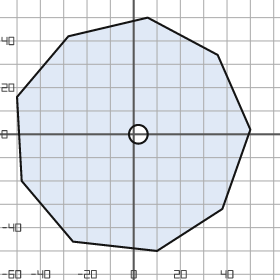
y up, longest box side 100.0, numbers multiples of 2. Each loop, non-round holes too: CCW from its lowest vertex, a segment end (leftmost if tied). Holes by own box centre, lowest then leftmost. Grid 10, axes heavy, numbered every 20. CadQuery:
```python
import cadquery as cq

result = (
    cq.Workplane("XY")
    .moveTo(10.0, -50.0)
    .lineTo(38.0, -32.0)
    .lineTo(50.0, 2.0)
    .lineTo(36.0, 34.0)
    .lineTo(6.0, 50.0)
    .lineTo(-28.0, 42.0)
    .lineTo(-50.0, 16.0)
    .lineTo(-48.0, -20.0)
    .lineTo(-26.0, -46.0)
    .close()
    .moveTo(2.0, 0.0)
    .circle(4.0)
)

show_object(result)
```